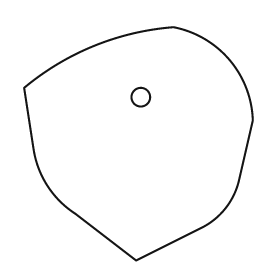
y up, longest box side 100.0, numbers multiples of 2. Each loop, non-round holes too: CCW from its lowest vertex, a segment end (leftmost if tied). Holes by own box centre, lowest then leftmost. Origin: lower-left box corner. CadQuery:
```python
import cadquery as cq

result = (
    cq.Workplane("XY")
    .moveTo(48.0, 0.0)
    .lineTo(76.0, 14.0)
    .threePointArc((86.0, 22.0), (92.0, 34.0))
    .lineTo(98.0, 60.0)
    .threePointArc((88.0, 86.0), (64.0, 100.0))
    .threePointArc((30.0, 92.0), (0.0, 74.0))
    .lineTo(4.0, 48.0)
    .threePointArc((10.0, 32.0), (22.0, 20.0))
    .close()
    .moveTo(50.0, 70.0)
    .circle(4.0)
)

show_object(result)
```